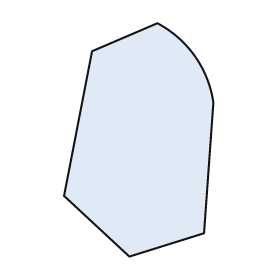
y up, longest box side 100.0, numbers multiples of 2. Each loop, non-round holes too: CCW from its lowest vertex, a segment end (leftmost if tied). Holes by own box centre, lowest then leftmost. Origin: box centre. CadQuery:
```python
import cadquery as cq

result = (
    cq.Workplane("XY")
    .moveTo(-4.0, -50.0)
    .lineTo(28.0, -40.0)
    .lineTo(32.0, 16.0)
    .threePointArc((24.0, 36.0), (8.0, 50.0))
    .lineTo(-20.0, 38.0)
    .lineTo(-32.0, -24.0)
    .close()
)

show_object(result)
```